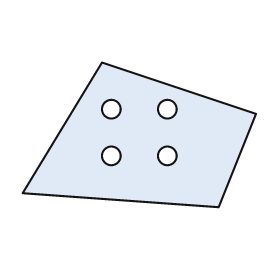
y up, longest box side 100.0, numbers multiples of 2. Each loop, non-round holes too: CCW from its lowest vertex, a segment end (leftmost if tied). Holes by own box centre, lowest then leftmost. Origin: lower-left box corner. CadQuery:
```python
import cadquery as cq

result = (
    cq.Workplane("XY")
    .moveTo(84.0, 0.0)
    .lineTo(100.0, 40.0)
    .lineTo(34.0, 62.0)
    .lineTo(0.0, 6.0)
    .close()
    .moveTo(38.0, 22.0)
    .circle(4.0)
    .moveTo(62.0, 22.0)
    .circle(4.0)
    .moveTo(38.0, 42.0)
    .circle(4.0)
    .moveTo(62.0, 42.0)
    .circle(4.0)
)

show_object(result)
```